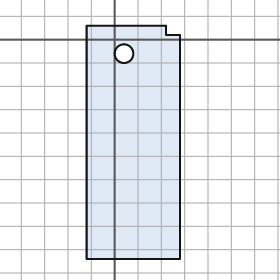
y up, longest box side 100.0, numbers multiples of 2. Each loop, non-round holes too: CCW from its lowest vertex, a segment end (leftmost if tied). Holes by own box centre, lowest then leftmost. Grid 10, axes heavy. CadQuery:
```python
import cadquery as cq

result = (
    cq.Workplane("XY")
    .moveTo(-12.0, -94.0)
    .lineTo(28.0, -94.0)
    .lineTo(28.0, 2.0)
    .lineTo(22.0, 2.0)
    .lineTo(22.0, 6.0)
    .lineTo(-12.0, 6.0)
    .close()
    .moveTo(4.0, -6.0)
    .circle(4.0)
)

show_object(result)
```